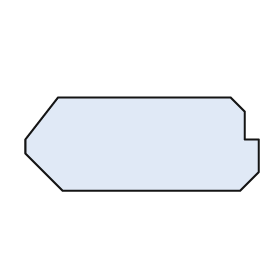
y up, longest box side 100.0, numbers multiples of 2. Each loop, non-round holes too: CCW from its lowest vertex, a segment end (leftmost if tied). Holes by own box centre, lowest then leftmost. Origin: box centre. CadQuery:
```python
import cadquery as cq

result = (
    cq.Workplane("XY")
    .moveTo(-34.0, -20.0)
    .lineTo(42.0, -20.0)
    .lineTo(50.0, -12.0)
    .lineTo(50.0, 2.0)
    .lineTo(44.0, 2.0)
    .lineTo(44.0, 14.0)
    .lineTo(38.0, 20.0)
    .lineTo(-36.0, 20.0)
    .lineTo(-50.0, 2.0)
    .lineTo(-50.0, -4.0)
    .close()
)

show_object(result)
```